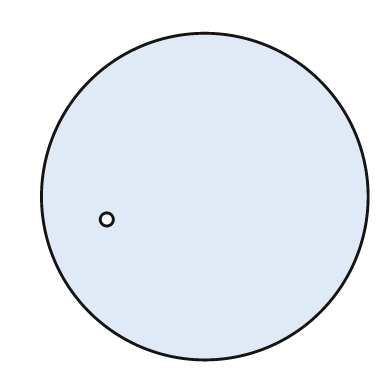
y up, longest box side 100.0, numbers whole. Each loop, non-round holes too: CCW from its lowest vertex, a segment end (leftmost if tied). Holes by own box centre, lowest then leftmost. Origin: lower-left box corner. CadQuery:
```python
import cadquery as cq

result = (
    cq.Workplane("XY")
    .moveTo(50.0, 50.0)
    .circle(50.0)
    .moveTo(20.0, 43.0)
    .circle(2.0)
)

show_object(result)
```